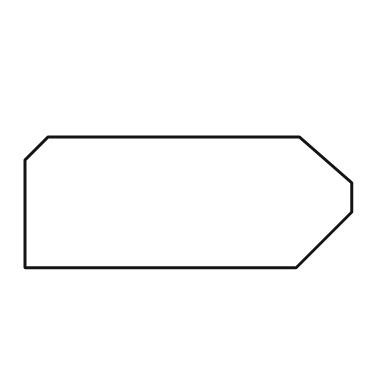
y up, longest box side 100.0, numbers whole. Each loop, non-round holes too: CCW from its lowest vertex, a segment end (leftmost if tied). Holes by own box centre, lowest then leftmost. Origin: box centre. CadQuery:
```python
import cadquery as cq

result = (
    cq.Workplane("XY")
    .moveTo(-50.0, -20.0)
    .lineTo(33.0, -20.0)
    .lineTo(50.0, -3.0)
    .lineTo(50.0, 6.0)
    .lineTo(34.0, 20.0)
    .lineTo(-43.0, 20.0)
    .lineTo(-50.0, 13.0)
    .close()
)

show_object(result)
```